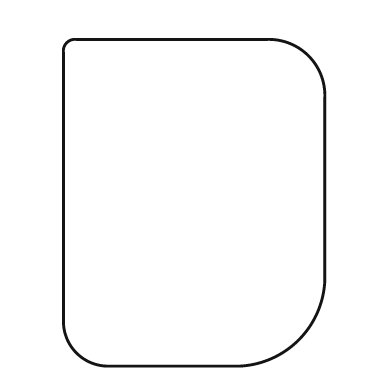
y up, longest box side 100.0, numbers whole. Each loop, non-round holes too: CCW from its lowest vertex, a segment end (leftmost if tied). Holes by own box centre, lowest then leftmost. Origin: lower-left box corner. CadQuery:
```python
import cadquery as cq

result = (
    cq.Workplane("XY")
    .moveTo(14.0, 0.0)
    .lineTo(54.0, 0.0)
    .threePointArc((72.0, 8.0), (80.0, 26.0))
    .lineTo(80.0, 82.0)
    .threePointArc((75.0, 95.0), (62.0, 100.0))
    .lineTo(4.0, 100.0)
    .threePointArc((1.0, 99.0), (0.0, 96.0))
    .lineTo(0.0, 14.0)
    .threePointArc((4.0, 4.0), (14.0, 0.0))
    .close()
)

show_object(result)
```